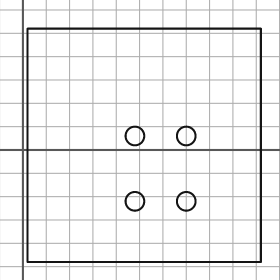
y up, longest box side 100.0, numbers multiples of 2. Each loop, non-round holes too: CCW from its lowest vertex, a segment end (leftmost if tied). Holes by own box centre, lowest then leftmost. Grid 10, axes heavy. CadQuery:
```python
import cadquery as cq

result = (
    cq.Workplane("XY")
    .moveTo(2.0, -48.0)
    .lineTo(102.0, -48.0)
    .lineTo(102.0, 52.0)
    .lineTo(2.0, 52.0)
    .close()
    .moveTo(48.0, -22.0)
    .circle(4.0)
    .moveTo(70.0, -22.0)
    .circle(4.0)
    .moveTo(48.0, 6.0)
    .circle(4.0)
    .moveTo(70.0, 6.0)
    .circle(4.0)
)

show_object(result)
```